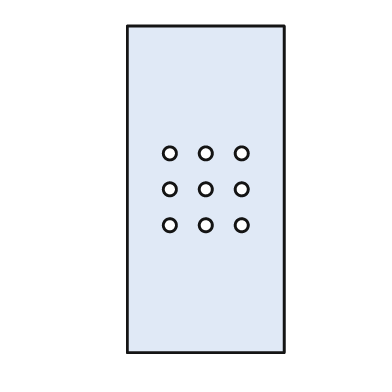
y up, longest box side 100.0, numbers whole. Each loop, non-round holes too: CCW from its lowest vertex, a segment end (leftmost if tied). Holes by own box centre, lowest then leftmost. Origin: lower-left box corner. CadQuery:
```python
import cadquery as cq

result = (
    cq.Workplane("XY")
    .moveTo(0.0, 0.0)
    .lineTo(48.0, 0.0)
    .lineTo(48.0, 100.0)
    .lineTo(0.0, 100.0)
    .close()
    .moveTo(13.0, 39.0)
    .circle(2.0)
    .moveTo(24.0, 39.0)
    .circle(2.0)
    .moveTo(35.0, 39.0)
    .circle(2.0)
    .moveTo(13.0, 50.0)
    .circle(2.0)
    .moveTo(24.0, 50.0)
    .circle(2.0)
    .moveTo(35.0, 50.0)
    .circle(2.0)
    .moveTo(13.0, 61.0)
    .circle(2.0)
    .moveTo(24.0, 61.0)
    .circle(2.0)
    .moveTo(35.0, 61.0)
    .circle(2.0)
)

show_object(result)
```